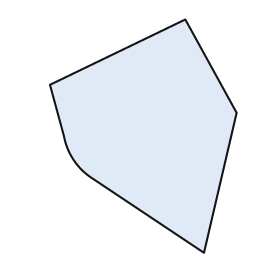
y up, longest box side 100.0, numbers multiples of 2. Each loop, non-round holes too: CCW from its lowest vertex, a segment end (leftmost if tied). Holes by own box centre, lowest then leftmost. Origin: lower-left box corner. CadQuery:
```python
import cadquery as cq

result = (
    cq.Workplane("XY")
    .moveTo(66.0, 0.0)
    .lineTo(80.0, 60.0)
    .lineTo(58.0, 100.0)
    .lineTo(0.0, 72.0)
    .lineTo(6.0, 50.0)
    .threePointArc((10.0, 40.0), (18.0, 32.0))
    .close()
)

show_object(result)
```